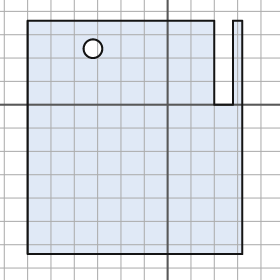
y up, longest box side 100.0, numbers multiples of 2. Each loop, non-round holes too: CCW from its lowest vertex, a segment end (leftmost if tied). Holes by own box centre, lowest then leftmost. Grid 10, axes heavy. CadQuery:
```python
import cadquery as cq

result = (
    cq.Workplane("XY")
    .moveTo(-60.0, -64.0)
    .lineTo(32.0, -64.0)
    .lineTo(32.0, 36.0)
    .lineTo(28.0, 36.0)
    .lineTo(28.0, 0.0)
    .lineTo(20.0, 0.0)
    .lineTo(20.0, 36.0)
    .lineTo(-60.0, 36.0)
    .close()
    .moveTo(-32.0, 24.0)
    .circle(4.0)
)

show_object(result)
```